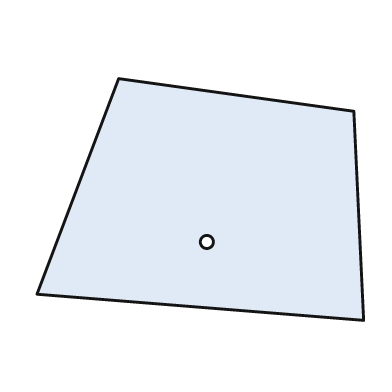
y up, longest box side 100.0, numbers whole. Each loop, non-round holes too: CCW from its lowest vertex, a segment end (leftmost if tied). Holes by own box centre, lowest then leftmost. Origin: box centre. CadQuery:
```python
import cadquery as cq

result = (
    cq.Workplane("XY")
    .moveTo(50.0, -37.0)
    .lineTo(47.0, 27.0)
    .lineTo(-25.0, 37.0)
    .lineTo(-50.0, -29.0)
    .close()
    .moveTo(2.0, -13.0)
    .circle(2.0)
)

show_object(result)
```